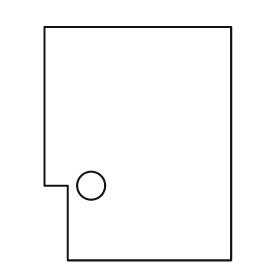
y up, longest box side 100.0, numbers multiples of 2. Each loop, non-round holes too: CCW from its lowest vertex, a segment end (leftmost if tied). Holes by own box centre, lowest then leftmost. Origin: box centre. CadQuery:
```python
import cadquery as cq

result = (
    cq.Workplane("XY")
    .moveTo(-30.0, -50.0)
    .lineTo(40.0, -50.0)
    .lineTo(40.0, 50.0)
    .lineTo(-40.0, 50.0)
    .lineTo(-40.0, -18.0)
    .lineTo(-30.0, -18.0)
    .close()
    .moveTo(-20.0, -18.0)
    .circle(6.0)
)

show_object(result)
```